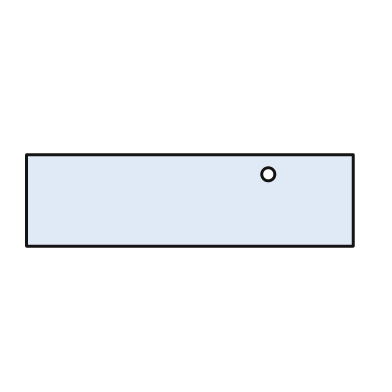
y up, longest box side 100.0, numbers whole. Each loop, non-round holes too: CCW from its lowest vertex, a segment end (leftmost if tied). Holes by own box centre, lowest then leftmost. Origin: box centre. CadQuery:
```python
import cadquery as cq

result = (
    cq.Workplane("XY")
    .moveTo(-50.0, -14.0)
    .lineTo(50.0, -14.0)
    .lineTo(50.0, 14.0)
    .lineTo(-50.0, 14.0)
    .close()
    .moveTo(24.0, 8.0)
    .circle(2.0)
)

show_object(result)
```